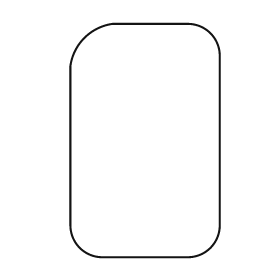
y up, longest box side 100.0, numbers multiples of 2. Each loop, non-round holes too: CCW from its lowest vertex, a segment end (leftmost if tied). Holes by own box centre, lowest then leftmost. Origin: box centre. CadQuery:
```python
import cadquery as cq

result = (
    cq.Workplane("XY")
    .moveTo(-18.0, -50.0)
    .lineTo(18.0, -50.0)
    .threePointArc((28.0, -46.0), (32.0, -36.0))
    .lineTo(32.0, 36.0)
    .threePointArc((28.0, 46.0), (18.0, 50.0))
    .lineTo(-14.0, 50.0)
    .threePointArc((-26.0, 44.0), (-32.0, 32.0))
    .lineTo(-32.0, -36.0)
    .threePointArc((-28.0, -46.0), (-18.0, -50.0))
    .close()
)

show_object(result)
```